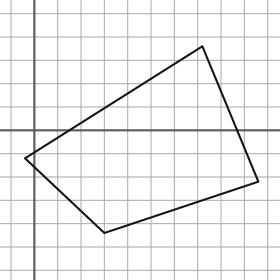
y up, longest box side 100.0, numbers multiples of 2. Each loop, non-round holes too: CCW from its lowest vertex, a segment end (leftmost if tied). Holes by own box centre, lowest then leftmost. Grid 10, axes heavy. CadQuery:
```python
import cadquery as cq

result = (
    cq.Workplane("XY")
    .moveTo(30.0, -44.0)
    .lineTo(96.0, -22.0)
    .lineTo(72.0, 36.0)
    .lineTo(-4.0, -12.0)
    .close()
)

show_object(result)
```